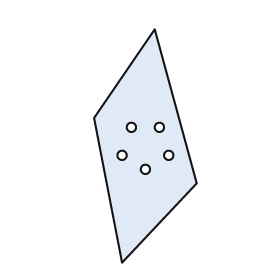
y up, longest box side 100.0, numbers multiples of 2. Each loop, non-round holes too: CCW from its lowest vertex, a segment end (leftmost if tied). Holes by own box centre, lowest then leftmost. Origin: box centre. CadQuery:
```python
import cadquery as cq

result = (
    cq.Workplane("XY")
    .moveTo(-10.0, -50.0)
    .lineTo(22.0, -16.0)
    .lineTo(4.0, 50.0)
    .lineTo(-22.0, 12.0)
    .close()
    .moveTo(0.0, -10.0)
    .circle(2.0)
    .moveTo(-10.0, -4.0)
    .circle(2.0)
    .moveTo(10.0, -4.0)
    .circle(2.0)
    .moveTo(-6.0, 8.0)
    .circle(2.0)
    .moveTo(6.0, 8.0)
    .circle(2.0)
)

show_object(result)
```